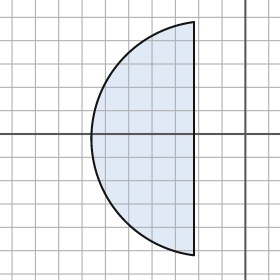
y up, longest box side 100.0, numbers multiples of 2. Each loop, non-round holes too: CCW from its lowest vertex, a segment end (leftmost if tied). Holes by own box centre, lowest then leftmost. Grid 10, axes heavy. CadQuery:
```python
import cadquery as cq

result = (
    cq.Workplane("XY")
    .moveTo(-22.0, -52.0)
    .lineTo(-22.0, 48.0)
    .threePointArc((-66.0, -2.0), (-22.0, -52.0))
    .close()
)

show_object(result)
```